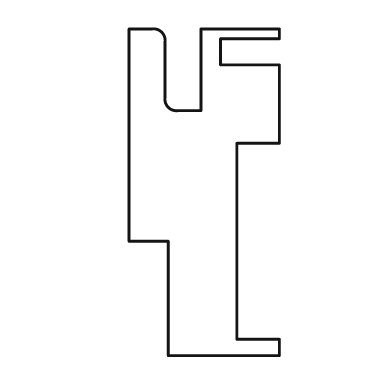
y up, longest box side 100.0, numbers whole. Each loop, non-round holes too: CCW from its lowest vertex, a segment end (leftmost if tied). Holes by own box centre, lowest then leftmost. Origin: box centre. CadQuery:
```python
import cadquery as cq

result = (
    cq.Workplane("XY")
    .moveTo(-11.0, -50.0)
    .lineTo(23.0, -50.0)
    .lineTo(23.0, -45.0)
    .lineTo(10.0, -45.0)
    .lineTo(10.0, 15.0)
    .lineTo(23.0, 15.0)
    .lineTo(23.0, 39.0)
    .lineTo(5.0, 39.0)
    .lineTo(5.0, 47.0)
    .lineTo(23.0, 47.0)
    .lineTo(23.0, 50.0)
    .lineTo(-1.0, 50.0)
    .lineTo(-1.0, 25.0)
    .lineTo(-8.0, 25.0)
    .threePointArc((-11.0, 26.0), (-12.0, 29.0))
    .lineTo(-12.0, 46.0)
    .threePointArc((-13.0, 49.0), (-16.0, 50.0))
    .lineTo(-23.0, 50.0)
    .lineTo(-23.0, -15.0)
    .lineTo(-11.0, -15.0)
    .close()
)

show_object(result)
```